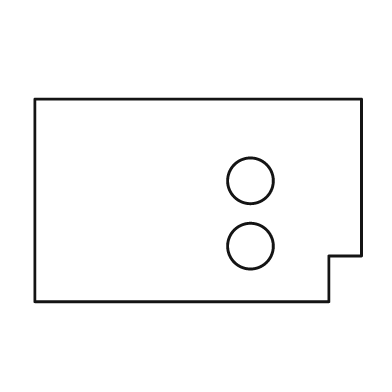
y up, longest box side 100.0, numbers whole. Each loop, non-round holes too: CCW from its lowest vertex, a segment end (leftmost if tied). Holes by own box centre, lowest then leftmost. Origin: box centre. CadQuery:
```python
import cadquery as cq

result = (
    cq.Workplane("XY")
    .moveTo(-50.0, -31.0)
    .lineTo(40.0, -31.0)
    .lineTo(40.0, -17.0)
    .lineTo(50.0, -17.0)
    .lineTo(50.0, 31.0)
    .lineTo(-50.0, 31.0)
    .close()
    .moveTo(16.0, -14.0)
    .circle(7.0)
    .moveTo(16.0, 6.0)
    .circle(7.0)
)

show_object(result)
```